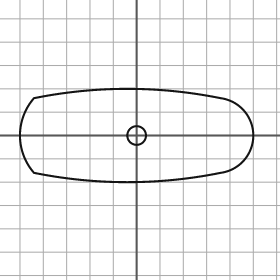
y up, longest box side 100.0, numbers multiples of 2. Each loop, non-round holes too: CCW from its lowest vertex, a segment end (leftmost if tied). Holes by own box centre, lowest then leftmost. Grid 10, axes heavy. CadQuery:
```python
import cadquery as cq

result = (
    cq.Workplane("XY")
    .moveTo(-44.0, -16.0)
    .threePointArc((-4.0, -20.0), (36.0, -16.0))
    .threePointArc((50.0, 0.0), (36.0, 16.0))
    .threePointArc((-4.0, 20.0), (-44.0, 16.0))
    .threePointArc((-50.0, 0.0), (-44.0, -16.0))
    .close()
    .moveTo(0.0, 0.0)
    .circle(4.0)
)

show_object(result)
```